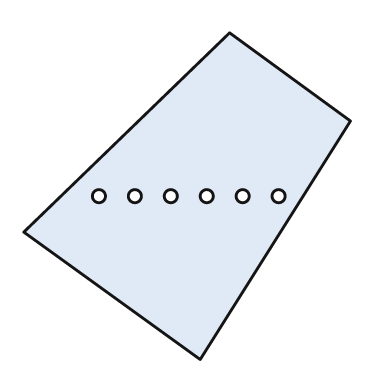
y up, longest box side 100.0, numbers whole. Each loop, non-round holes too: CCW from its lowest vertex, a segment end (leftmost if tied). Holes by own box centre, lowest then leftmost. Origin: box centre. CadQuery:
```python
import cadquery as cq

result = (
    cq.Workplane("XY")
    .moveTo(4.0, -50.0)
    .lineTo(50.0, 23.0)
    .lineTo(13.0, 50.0)
    .lineTo(-50.0, -11.0)
    .close()
    .moveTo(-27.0, 0.0)
    .circle(2.0)
    .moveTo(-16.0, 0.0)
    .circle(2.0)
    .moveTo(-5.0, 0.0)
    .circle(2.0)
    .moveTo(6.0, 0.0)
    .circle(2.0)
    .moveTo(17.0, 0.0)
    .circle(2.0)
    .moveTo(28.0, 0.0)
    .circle(2.0)
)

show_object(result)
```